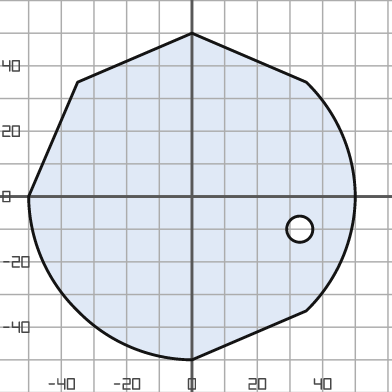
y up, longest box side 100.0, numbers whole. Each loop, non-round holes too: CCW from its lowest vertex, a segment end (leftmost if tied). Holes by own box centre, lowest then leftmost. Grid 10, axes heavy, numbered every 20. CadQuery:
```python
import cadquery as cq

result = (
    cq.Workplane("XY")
    .moveTo(0.0, -50.0)
    .lineTo(35.0, -35.0)
    .threePointArc((46.0, -19.0), (50.0, 0.0))
    .threePointArc((46.0, 19.0), (35.0, 35.0))
    .lineTo(0.0, 50.0)
    .lineTo(-35.0, 35.0)
    .lineTo(-50.0, 0.0)
    .threePointArc((-46.0, -19.0), (-35.0, -35.0))
    .threePointArc((-19.0, -46.0), (0.0, -50.0))
    .close()
    .moveTo(33.0, -10.0)
    .circle(4.0)
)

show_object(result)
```